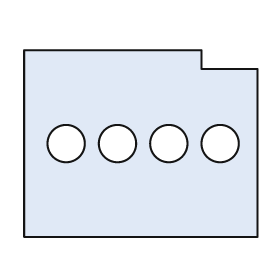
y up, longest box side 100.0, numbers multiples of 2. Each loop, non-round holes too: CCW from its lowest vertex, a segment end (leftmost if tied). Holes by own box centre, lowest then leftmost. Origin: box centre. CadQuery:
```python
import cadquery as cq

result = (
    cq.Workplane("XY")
    .moveTo(-50.0, -40.0)
    .lineTo(50.0, -40.0)
    .lineTo(50.0, 32.0)
    .lineTo(26.0, 32.0)
    .lineTo(26.0, 40.0)
    .lineTo(-50.0, 40.0)
    .close()
    .moveTo(-32.0, 0.0)
    .circle(8.0)
    .moveTo(-10.0, 0.0)
    .circle(8.0)
    .moveTo(12.0, 0.0)
    .circle(8.0)
    .moveTo(34.0, 0.0)
    .circle(8.0)
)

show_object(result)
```